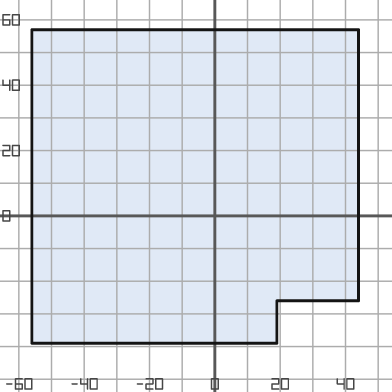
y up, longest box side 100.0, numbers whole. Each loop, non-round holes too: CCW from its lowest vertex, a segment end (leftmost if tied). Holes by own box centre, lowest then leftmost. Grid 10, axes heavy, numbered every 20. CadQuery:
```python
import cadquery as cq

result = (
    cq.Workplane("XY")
    .moveTo(-56.0, -39.0)
    .lineTo(19.0, -39.0)
    .lineTo(19.0, -26.0)
    .lineTo(44.0, -26.0)
    .lineTo(44.0, 57.0)
    .lineTo(-56.0, 57.0)
    .close()
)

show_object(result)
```